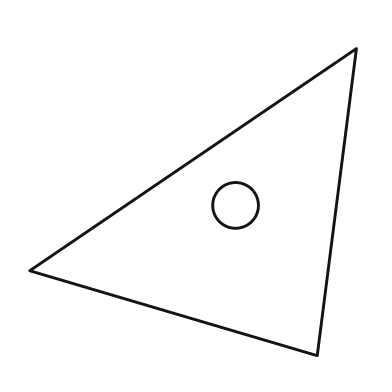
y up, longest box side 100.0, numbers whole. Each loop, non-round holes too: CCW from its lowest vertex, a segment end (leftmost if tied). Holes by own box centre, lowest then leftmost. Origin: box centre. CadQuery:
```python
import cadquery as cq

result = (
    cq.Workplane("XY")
    .moveTo(38.0, -47.0)
    .lineTo(50.0, 47.0)
    .lineTo(-50.0, -21.0)
    .close()
    .moveTo(13.0, -1.0)
    .circle(7.0)
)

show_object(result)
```